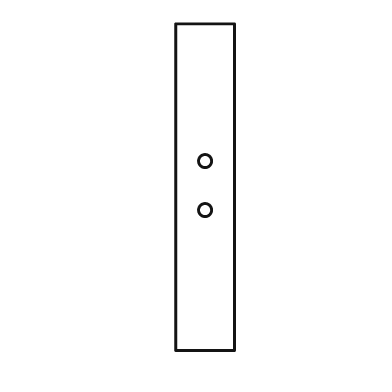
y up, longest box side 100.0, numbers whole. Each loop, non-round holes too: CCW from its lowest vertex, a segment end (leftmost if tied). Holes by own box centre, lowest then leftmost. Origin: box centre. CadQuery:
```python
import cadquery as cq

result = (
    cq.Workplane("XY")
    .moveTo(-9.0, -50.0)
    .lineTo(9.0, -50.0)
    .lineTo(9.0, 50.0)
    .lineTo(-9.0, 50.0)
    .close()
    .moveTo(0.0, -7.0)
    .circle(2.0)
    .moveTo(0.0, 8.0)
    .circle(2.0)
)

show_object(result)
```